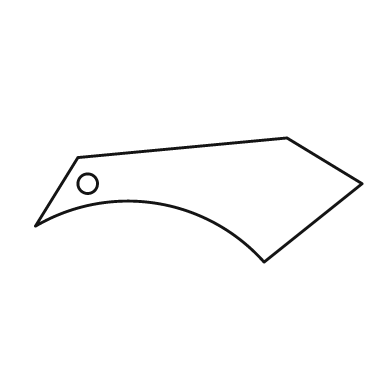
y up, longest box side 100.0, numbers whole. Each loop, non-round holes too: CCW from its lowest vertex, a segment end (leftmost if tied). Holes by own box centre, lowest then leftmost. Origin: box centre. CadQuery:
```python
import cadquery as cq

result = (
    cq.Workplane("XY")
    .moveTo(20.0, -19.0)
    .lineTo(50.0, 5.0)
    .lineTo(27.0, 19.0)
    .lineTo(-37.0, 13.0)
    .lineTo(-50.0, -8.0)
    .threePointArc((-13.0, -1.0), (20.0, -19.0))
    .close()
    .moveTo(-34.0, 5.0)
    .circle(3.0)
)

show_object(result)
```